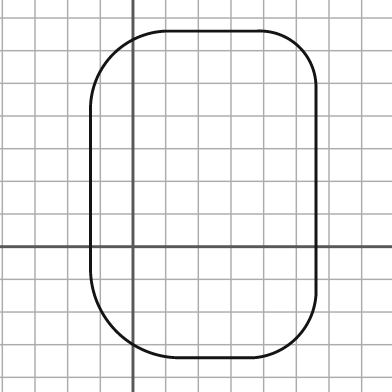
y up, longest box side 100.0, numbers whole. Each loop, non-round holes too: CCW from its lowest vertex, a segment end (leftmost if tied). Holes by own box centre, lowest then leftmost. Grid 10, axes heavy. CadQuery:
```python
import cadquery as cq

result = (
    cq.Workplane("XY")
    .moveTo(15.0, -34.0)
    .lineTo(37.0, -34.0)
    .threePointArc((50.0, -28.0), (56.0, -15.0))
    .lineTo(56.0, 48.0)
    .threePointArc((51.0, 61.0), (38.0, 66.0))
    .lineTo(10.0, 66.0)
    .threePointArc((-6.0, 59.0), (-13.0, 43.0))
    .lineTo(-13.0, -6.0)
    .threePointArc((-5.0, -26.0), (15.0, -34.0))
    .close()
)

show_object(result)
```